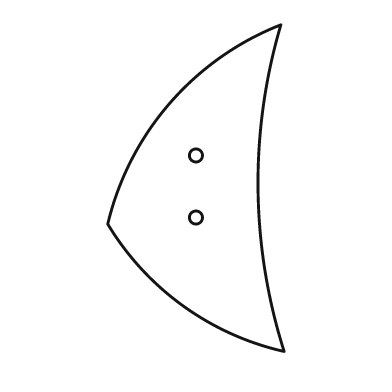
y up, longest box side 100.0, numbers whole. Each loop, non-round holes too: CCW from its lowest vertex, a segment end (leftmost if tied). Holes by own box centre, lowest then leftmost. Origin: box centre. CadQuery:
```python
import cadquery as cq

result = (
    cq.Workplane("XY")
    .moveTo(27.0, -50.0)
    .threePointArc((19.0, 0.0), (26.0, 50.0))
    .threePointArc((-8.0, 26.0), (-27.0, -11.0))
    .threePointArc((-4.0, -36.0), (27.0, -50.0))
    .close()
    .moveTo(0.0, -9.0)
    .circle(2.0)
    .moveTo(0.0, 10.0)
    .circle(2.0)
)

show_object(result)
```